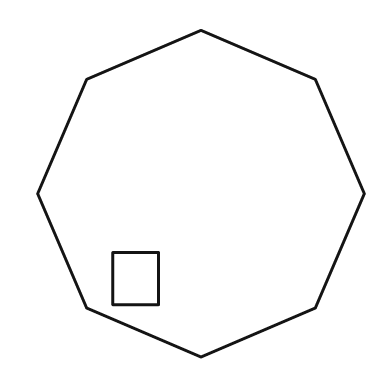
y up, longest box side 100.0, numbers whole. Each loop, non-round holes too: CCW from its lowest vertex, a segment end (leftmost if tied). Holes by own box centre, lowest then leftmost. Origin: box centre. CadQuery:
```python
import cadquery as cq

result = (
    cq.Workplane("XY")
    .moveTo(0.0, -50.0)
    .lineTo(35.0, -35.0)
    .lineTo(50.0, 0.0)
    .lineTo(35.0, 35.0)
    .lineTo(0.0, 50.0)
    .lineTo(-35.0, 35.0)
    .lineTo(-50.0, 0.0)
    .lineTo(-35.0, -35.0)
    .close()
    .moveTo(-27.0, -34.0)
    .lineTo(-13.0, -34.0)
    .lineTo(-13.0, -18.0)
    .lineTo(-27.0, -18.0)
    .close()
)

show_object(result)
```